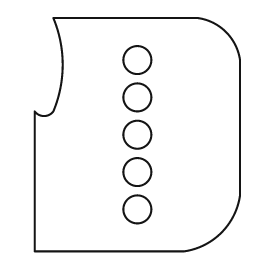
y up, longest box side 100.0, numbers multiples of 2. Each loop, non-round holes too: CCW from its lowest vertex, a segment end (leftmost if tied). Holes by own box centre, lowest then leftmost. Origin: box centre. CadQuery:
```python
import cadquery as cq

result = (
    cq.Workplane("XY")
    .moveTo(-44.0, -50.0)
    .lineTo(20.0, -50.0)
    .threePointArc((36.0, -42.0), (44.0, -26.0))
    .lineTo(44.0, 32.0)
    .threePointArc((38.0, 44.0), (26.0, 50.0))
    .lineTo(-36.0, 50.0)
    .threePointArc((-32.0, 30.0), (-36.0, 10.0))
    .threePointArc((-40.0, 8.0), (-44.0, 10.0))
    .close()
    .moveTo(0.0, -32.0)
    .circle(6.0)
    .moveTo(0.0, -16.0)
    .circle(6.0)
    .moveTo(0.0, 0.0)
    .circle(6.0)
    .moveTo(0.0, 16.0)
    .circle(6.0)
    .moveTo(0.0, 32.0)
    .circle(6.0)
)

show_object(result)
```